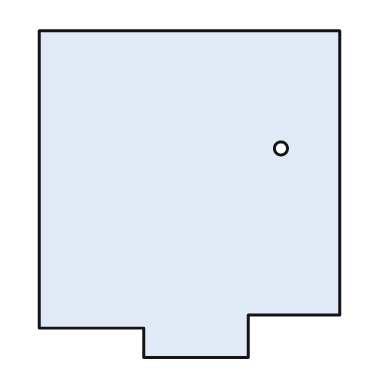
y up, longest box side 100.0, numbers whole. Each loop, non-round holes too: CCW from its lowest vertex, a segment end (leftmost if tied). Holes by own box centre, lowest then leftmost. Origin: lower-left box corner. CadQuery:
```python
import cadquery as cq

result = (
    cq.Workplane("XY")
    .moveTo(32.0, 0.0)
    .lineTo(64.0, 0.0)
    .lineTo(64.0, 13.0)
    .lineTo(92.0, 13.0)
    .lineTo(92.0, 100.0)
    .lineTo(0.0, 100.0)
    .lineTo(0.0, 9.0)
    .lineTo(32.0, 9.0)
    .close()
    .moveTo(74.0, 64.0)
    .circle(2.0)
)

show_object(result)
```